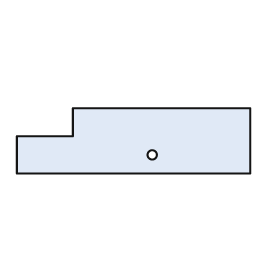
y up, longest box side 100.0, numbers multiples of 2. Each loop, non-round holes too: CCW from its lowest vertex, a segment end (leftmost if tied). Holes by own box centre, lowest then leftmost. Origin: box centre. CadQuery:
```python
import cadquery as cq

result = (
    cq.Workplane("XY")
    .moveTo(-50.0, -14.0)
    .lineTo(50.0, -14.0)
    .lineTo(50.0, 14.0)
    .lineTo(-26.0, 14.0)
    .lineTo(-26.0, 2.0)
    .lineTo(-50.0, 2.0)
    .close()
    .moveTo(8.0, -6.0)
    .circle(2.0)
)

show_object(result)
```